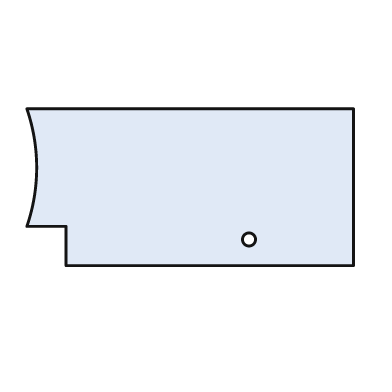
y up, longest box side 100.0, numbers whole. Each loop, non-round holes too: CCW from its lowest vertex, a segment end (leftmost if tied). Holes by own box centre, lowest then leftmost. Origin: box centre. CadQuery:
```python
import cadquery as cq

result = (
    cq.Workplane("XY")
    .moveTo(-38.0, -24.0)
    .lineTo(50.0, -24.0)
    .lineTo(50.0, 24.0)
    .lineTo(-50.0, 24.0)
    .threePointArc((-47.0, 6.0), (-50.0, -12.0))
    .lineTo(-38.0, -12.0)
    .close()
    .moveTo(18.0, -16.0)
    .circle(2.0)
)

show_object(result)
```